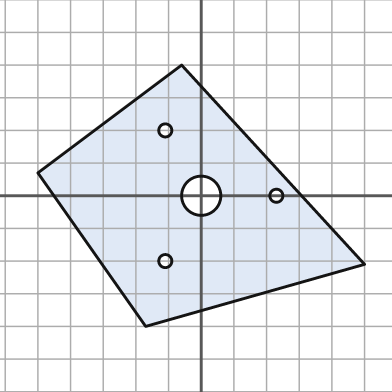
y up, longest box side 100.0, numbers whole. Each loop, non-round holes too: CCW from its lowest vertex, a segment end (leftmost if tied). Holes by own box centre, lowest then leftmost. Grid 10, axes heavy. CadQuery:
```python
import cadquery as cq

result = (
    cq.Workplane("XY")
    .moveTo(-17.0, -40.0)
    .lineTo(50.0, -21.0)
    .lineTo(-6.0, 40.0)
    .lineTo(-50.0, 7.0)
    .close()
    .moveTo(-11.0, -20.0)
    .circle(2.0)
    .moveTo(0.0, 0.0)
    .circle(6.0)
    .moveTo(23.0, 0.0)
    .circle(2.0)
    .moveTo(-11.0, 20.0)
    .circle(2.0)
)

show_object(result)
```